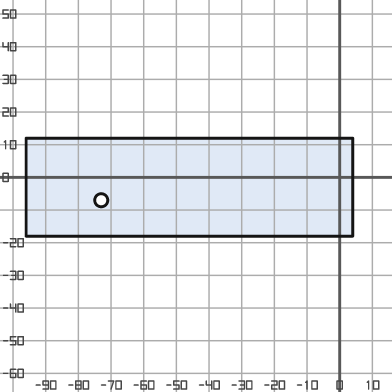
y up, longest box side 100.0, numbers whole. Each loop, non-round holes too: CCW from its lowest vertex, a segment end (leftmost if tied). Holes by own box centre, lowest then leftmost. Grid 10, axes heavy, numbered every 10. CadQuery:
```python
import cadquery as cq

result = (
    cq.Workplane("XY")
    .moveTo(-96.0, -18.0)
    .lineTo(4.0, -18.0)
    .lineTo(4.0, 12.0)
    .lineTo(-96.0, 12.0)
    .close()
    .moveTo(-73.0, -7.0)
    .circle(2.0)
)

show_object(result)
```